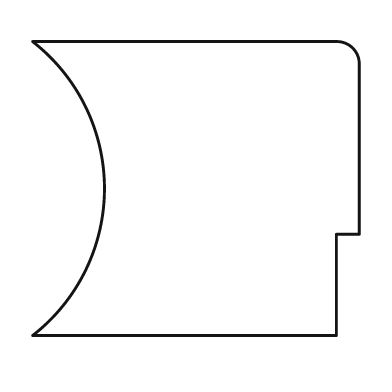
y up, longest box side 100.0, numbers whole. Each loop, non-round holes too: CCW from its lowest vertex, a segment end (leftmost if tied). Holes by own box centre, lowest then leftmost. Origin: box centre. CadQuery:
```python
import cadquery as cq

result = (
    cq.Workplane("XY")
    .moveTo(-50.0, -45.0)
    .lineTo(43.0, -45.0)
    .lineTo(43.0, -14.0)
    .lineTo(50.0, -14.0)
    .lineTo(50.0, 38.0)
    .threePointArc((48.0, 43.0), (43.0, 45.0))
    .lineTo(-50.0, 45.0)
    .threePointArc((-28.0, 0.0), (-50.0, -45.0))
    .close()
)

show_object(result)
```